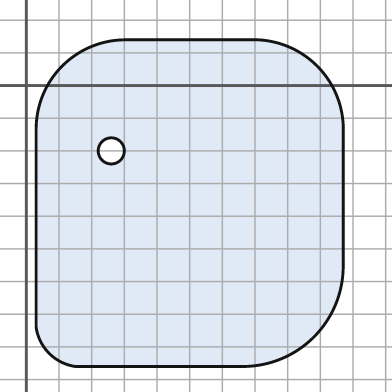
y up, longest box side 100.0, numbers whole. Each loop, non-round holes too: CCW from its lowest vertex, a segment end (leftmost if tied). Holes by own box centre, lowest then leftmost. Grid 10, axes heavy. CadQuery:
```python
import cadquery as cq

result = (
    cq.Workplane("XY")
    .moveTo(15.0, -86.0)
    .lineTo(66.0, -86.0)
    .threePointArc((88.0, -77.0), (97.0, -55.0))
    .lineTo(97.0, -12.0)
    .threePointArc((89.0, 6.0), (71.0, 14.0))
    .lineTo(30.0, 14.0)
    .threePointArc((11.0, 6.0), (3.0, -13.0))
    .lineTo(3.0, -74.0)
    .threePointArc((7.0, -82.0), (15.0, -86.0))
    .close()
    .moveTo(26.0, -20.0)
    .circle(4.0)
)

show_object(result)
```